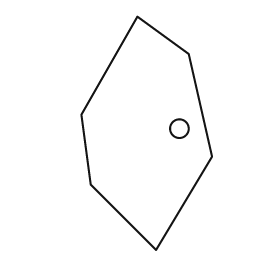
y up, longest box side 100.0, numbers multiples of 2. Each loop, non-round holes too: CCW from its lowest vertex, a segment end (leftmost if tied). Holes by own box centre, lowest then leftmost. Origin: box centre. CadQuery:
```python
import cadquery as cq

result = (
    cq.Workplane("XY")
    .moveTo(4.0, -50.0)
    .lineTo(28.0, -10.0)
    .lineTo(18.0, 34.0)
    .lineTo(-4.0, 50.0)
    .lineTo(-28.0, 8.0)
    .lineTo(-24.0, -22.0)
    .close()
    .moveTo(14.0, 2.0)
    .circle(4.0)
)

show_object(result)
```